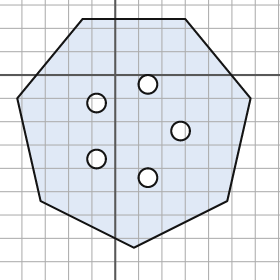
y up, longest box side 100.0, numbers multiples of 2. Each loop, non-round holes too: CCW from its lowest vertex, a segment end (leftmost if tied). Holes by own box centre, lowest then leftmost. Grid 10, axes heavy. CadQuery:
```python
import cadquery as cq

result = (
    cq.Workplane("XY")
    .moveTo(8.0, -74.0)
    .lineTo(48.0, -54.0)
    .lineTo(58.0, -10.0)
    .lineTo(30.0, 24.0)
    .lineTo(-14.0, 24.0)
    .lineTo(-42.0, -10.0)
    .lineTo(-32.0, -54.0)
    .close()
    .moveTo(14.0, -44.0)
    .circle(4.0)
    .moveTo(-8.0, -36.0)
    .circle(4.0)
    .moveTo(28.0, -24.0)
    .circle(4.0)
    .moveTo(-8.0, -12.0)
    .circle(4.0)
    .moveTo(14.0, -4.0)
    .circle(4.0)
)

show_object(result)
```